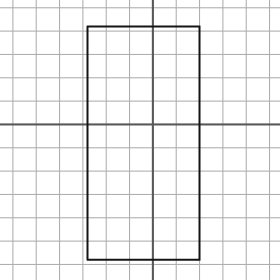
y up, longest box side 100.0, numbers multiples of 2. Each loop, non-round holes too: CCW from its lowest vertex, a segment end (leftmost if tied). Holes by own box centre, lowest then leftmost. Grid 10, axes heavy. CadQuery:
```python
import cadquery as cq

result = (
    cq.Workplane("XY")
    .moveTo(-28.0, -58.0)
    .lineTo(20.0, -58.0)
    .lineTo(20.0, 42.0)
    .lineTo(-28.0, 42.0)
    .close()
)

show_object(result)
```